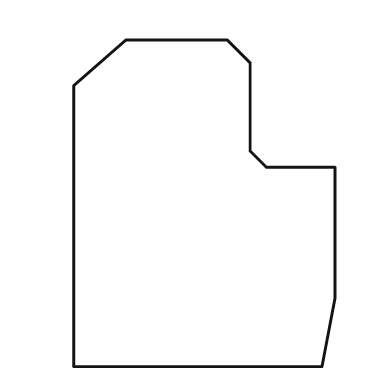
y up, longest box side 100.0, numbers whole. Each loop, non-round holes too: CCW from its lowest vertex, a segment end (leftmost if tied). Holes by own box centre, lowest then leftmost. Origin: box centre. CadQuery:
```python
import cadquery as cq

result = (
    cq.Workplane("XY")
    .moveTo(-40.0, -50.0)
    .lineTo(36.0, -50.0)
    .lineTo(40.0, -29.0)
    .lineTo(40.0, 11.0)
    .lineTo(19.0, 11.0)
    .lineTo(14.0, 16.0)
    .lineTo(14.0, 43.0)
    .lineTo(7.0, 50.0)
    .lineTo(-24.0, 50.0)
    .lineTo(-40.0, 36.0)
    .close()
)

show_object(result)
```